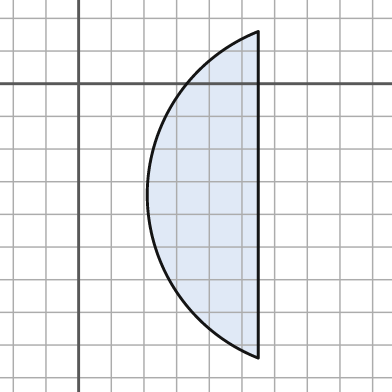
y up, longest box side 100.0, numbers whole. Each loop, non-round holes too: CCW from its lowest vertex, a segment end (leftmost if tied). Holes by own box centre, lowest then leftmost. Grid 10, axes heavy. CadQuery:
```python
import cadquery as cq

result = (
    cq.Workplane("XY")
    .moveTo(55.0, -84.0)
    .lineTo(55.0, 16.0)
    .threePointArc((21.0, -34.0), (55.0, -84.0))
    .close()
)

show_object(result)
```